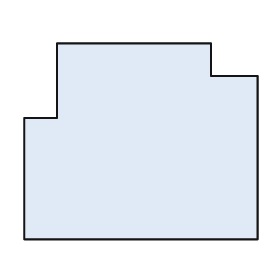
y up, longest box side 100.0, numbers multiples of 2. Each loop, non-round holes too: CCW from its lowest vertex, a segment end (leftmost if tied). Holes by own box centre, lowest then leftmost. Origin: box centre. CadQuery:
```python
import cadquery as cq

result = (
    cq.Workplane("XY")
    .moveTo(-50.0, -42.0)
    .lineTo(50.0, -42.0)
    .lineTo(50.0, 28.0)
    .lineTo(30.0, 28.0)
    .lineTo(30.0, 42.0)
    .lineTo(-36.0, 42.0)
    .lineTo(-36.0, 10.0)
    .lineTo(-50.0, 10.0)
    .close()
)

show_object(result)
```